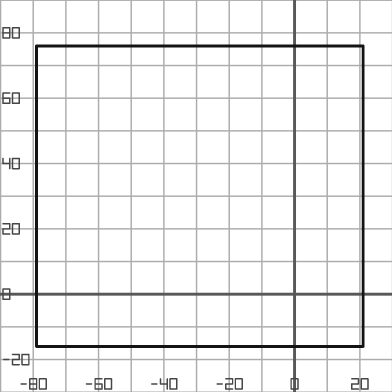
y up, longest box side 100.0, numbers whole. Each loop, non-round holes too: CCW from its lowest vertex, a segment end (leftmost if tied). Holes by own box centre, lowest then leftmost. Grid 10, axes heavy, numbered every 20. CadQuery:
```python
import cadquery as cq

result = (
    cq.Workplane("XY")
    .moveTo(-79.0, -16.0)
    .lineTo(21.0, -16.0)
    .lineTo(21.0, 76.0)
    .lineTo(-79.0, 76.0)
    .close()
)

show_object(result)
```